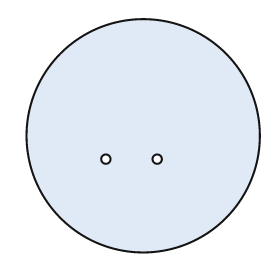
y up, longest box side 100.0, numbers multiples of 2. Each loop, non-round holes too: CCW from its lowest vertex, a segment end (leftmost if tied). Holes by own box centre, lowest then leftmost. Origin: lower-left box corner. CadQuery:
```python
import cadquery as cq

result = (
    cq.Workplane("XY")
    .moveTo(50.0, 50.0)
    .circle(50.0)
    .moveTo(34.0, 40.0)
    .circle(2.0)
    .moveTo(56.0, 40.0)
    .circle(2.0)
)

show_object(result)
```